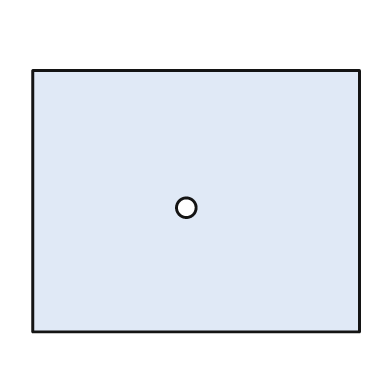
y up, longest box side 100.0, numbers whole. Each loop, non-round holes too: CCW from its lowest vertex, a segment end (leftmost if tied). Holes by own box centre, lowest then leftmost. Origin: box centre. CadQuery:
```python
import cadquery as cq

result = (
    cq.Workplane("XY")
    .moveTo(-50.0, -40.0)
    .lineTo(50.0, -40.0)
    .lineTo(50.0, 40.0)
    .lineTo(-50.0, 40.0)
    .close()
    .moveTo(-3.0, -2.0)
    .circle(3.0)
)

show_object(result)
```